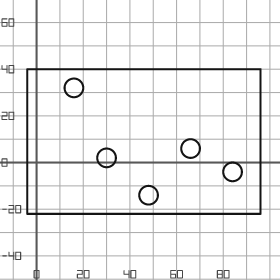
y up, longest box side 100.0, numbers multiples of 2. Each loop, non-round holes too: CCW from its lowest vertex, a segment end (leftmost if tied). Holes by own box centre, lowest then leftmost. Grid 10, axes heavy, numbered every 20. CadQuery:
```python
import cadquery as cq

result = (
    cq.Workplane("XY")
    .moveTo(-4.0, -22.0)
    .lineTo(96.0, -22.0)
    .lineTo(96.0, 40.0)
    .lineTo(-4.0, 40.0)
    .close()
    .moveTo(48.0, -14.0)
    .circle(4.0)
    .moveTo(84.0, -4.0)
    .circle(4.0)
    .moveTo(30.0, 2.0)
    .circle(4.0)
    .moveTo(66.0, 6.0)
    .circle(4.0)
    .moveTo(16.0, 32.0)
    .circle(4.0)
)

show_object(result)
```